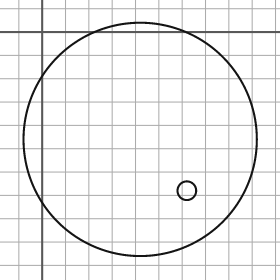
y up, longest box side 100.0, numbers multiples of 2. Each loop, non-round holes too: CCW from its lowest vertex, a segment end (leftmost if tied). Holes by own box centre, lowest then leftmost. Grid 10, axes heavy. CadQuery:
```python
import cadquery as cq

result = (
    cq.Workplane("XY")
    .moveTo(42.0, -46.0)
    .circle(50.0)
    .moveTo(62.0, -68.0)
    .circle(4.0)
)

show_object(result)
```